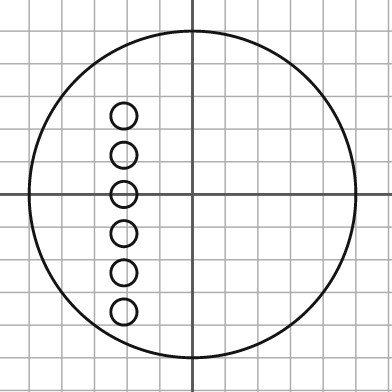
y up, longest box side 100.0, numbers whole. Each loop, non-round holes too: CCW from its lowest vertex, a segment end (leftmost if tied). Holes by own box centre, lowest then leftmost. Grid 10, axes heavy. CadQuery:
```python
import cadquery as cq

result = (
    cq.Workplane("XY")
    .moveTo(0.0, 0.0)
    .circle(50.0)
    .moveTo(-21.0, -36.0)
    .circle(4.0)
    .moveTo(-21.0, -24.0)
    .circle(4.0)
    .moveTo(-21.0, -12.0)
    .circle(4.0)
    .moveTo(-21.0, 0.0)
    .circle(4.0)
    .moveTo(-21.0, 12.0)
    .circle(4.0)
    .moveTo(-21.0, 24.0)
    .circle(4.0)
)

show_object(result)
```